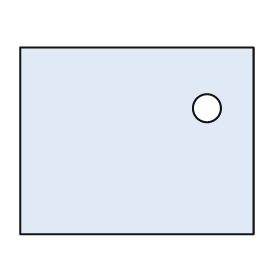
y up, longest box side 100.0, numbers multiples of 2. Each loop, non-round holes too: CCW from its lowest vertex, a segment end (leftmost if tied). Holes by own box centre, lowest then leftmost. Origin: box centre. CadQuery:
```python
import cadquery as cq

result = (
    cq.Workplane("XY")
    .moveTo(-50.0, -40.0)
    .lineTo(50.0, -40.0)
    .lineTo(50.0, 40.0)
    .lineTo(-50.0, 40.0)
    .close()
    .moveTo(30.0, 14.0)
    .circle(6.0)
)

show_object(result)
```